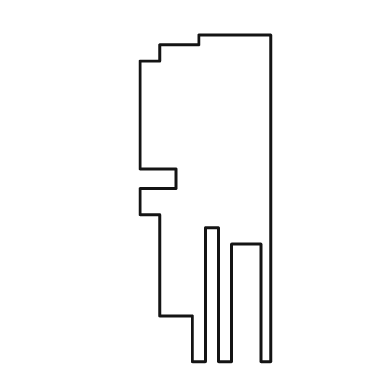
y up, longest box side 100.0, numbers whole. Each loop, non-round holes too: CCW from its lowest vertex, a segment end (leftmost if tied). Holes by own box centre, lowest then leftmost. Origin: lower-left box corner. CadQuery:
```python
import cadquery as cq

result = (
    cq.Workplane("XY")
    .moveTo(16.0, 0.0)
    .lineTo(20.0, 0.0)
    .lineTo(20.0, 41.0)
    .lineTo(24.0, 41.0)
    .lineTo(24.0, 0.0)
    .lineTo(28.0, 0.0)
    .lineTo(28.0, 36.0)
    .lineTo(37.0, 36.0)
    .lineTo(37.0, 0.0)
    .lineTo(40.0, 0.0)
    .lineTo(40.0, 100.0)
    .lineTo(18.0, 100.0)
    .lineTo(18.0, 97.0)
    .lineTo(6.0, 97.0)
    .lineTo(6.0, 92.0)
    .lineTo(0.0, 92.0)
    .lineTo(0.0, 59.0)
    .lineTo(11.0, 59.0)
    .lineTo(11.0, 53.0)
    .lineTo(0.0, 53.0)
    .lineTo(0.0, 45.0)
    .lineTo(6.0, 45.0)
    .lineTo(6.0, 14.0)
    .lineTo(16.0, 14.0)
    .close()
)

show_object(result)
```